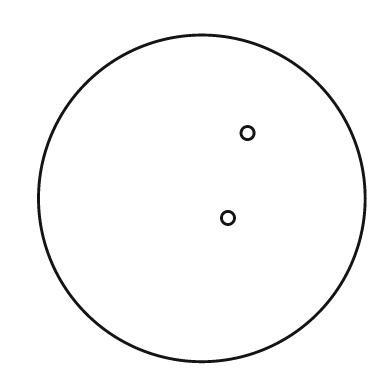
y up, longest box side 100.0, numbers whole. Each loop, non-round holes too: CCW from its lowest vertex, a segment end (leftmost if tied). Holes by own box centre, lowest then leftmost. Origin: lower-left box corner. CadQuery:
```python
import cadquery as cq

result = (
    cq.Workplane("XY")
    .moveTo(50.0, 50.0)
    .circle(50.0)
    .moveTo(58.0, 44.0)
    .circle(2.0)
    .moveTo(64.0, 70.0)
    .circle(2.0)
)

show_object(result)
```